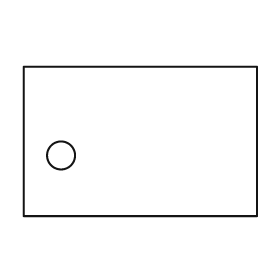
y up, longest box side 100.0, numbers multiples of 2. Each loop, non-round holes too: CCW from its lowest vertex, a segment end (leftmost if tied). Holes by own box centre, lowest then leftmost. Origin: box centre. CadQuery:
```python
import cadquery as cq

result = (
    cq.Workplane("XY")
    .moveTo(-50.0, -32.0)
    .lineTo(50.0, -32.0)
    .lineTo(50.0, 32.0)
    .lineTo(-50.0, 32.0)
    .close()
    .moveTo(-34.0, -6.0)
    .circle(6.0)
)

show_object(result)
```